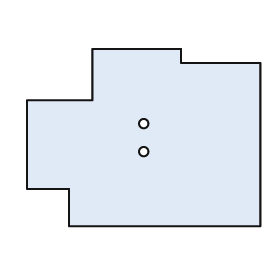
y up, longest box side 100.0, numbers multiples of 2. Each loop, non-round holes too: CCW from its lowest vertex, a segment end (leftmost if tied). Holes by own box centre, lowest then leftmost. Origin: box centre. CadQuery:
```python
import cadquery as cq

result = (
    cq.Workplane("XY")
    .moveTo(-32.0, -38.0)
    .lineTo(50.0, -38.0)
    .lineTo(50.0, 32.0)
    .lineTo(16.0, 32.0)
    .lineTo(16.0, 38.0)
    .lineTo(-22.0, 38.0)
    .lineTo(-22.0, 16.0)
    .lineTo(-50.0, 16.0)
    .lineTo(-50.0, -22.0)
    .lineTo(-32.0, -22.0)
    .close()
    .moveTo(0.0, -6.0)
    .circle(2.0)
    .moveTo(0.0, 6.0)
    .circle(2.0)
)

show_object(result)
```